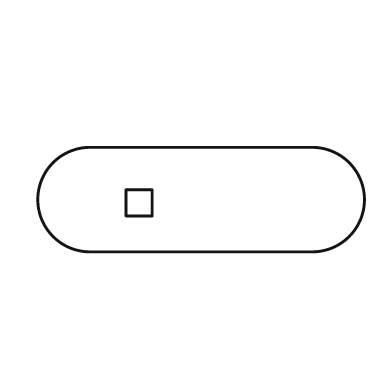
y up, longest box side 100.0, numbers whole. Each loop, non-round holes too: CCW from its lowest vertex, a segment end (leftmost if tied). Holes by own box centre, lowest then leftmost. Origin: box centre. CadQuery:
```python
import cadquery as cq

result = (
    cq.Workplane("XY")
    .moveTo(-34.0, -16.0)
    .lineTo(34.0, -16.0)
    .threePointArc((50.0, 0.0), (34.0, 16.0))
    .lineTo(-34.0, 16.0)
    .threePointArc((-50.0, 0.0), (-34.0, -16.0))
    .close()
    .moveTo(-23.0, -5.0)
    .lineTo(-15.0, -5.0)
    .lineTo(-15.0, 3.0)
    .lineTo(-23.0, 3.0)
    .close()
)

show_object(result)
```